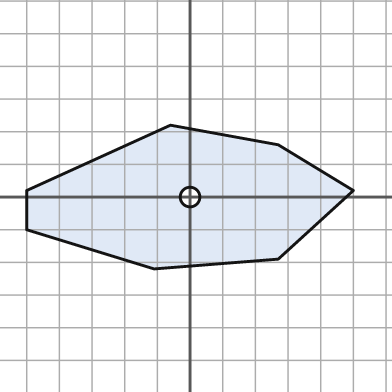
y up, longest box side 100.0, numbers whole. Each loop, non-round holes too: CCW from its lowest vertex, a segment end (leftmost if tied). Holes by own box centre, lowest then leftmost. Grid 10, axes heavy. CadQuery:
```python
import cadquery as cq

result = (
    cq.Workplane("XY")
    .moveTo(-11.0, -22.0)
    .lineTo(27.0, -19.0)
    .lineTo(50.0, 2.0)
    .lineTo(27.0, 16.0)
    .lineTo(-6.0, 22.0)
    .lineTo(-50.0, 2.0)
    .lineTo(-50.0, -10.0)
    .close()
    .moveTo(0.0, 0.0)
    .circle(3.0)
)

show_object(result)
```